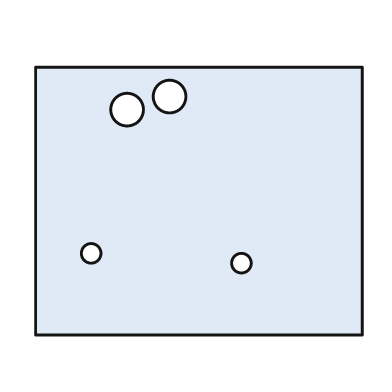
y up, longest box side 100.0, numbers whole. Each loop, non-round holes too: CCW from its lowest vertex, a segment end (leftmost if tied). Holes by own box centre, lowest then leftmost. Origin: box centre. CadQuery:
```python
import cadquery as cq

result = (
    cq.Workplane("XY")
    .moveTo(-50.0, -41.0)
    .lineTo(50.0, -41.0)
    .lineTo(50.0, 41.0)
    .lineTo(-50.0, 41.0)
    .close()
    .moveTo(13.0, -19.0)
    .circle(3.0)
    .moveTo(-33.0, -16.0)
    .circle(3.0)
    .moveTo(-22.0, 28.0)
    .circle(5.0)
    .moveTo(-9.0, 32.0)
    .circle(5.0)
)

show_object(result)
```